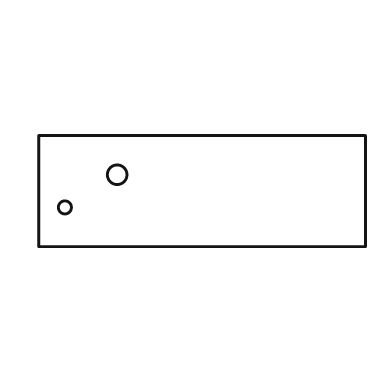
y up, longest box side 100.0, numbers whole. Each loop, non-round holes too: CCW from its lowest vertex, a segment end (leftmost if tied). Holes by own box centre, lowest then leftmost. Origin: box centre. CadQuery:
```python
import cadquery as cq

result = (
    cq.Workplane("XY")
    .moveTo(-50.0, -17.0)
    .lineTo(50.0, -17.0)
    .lineTo(50.0, 17.0)
    .lineTo(-50.0, 17.0)
    .close()
    .moveTo(-42.0, -5.0)
    .circle(2.0)
    .moveTo(-26.0, 5.0)
    .circle(3.0)
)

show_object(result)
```